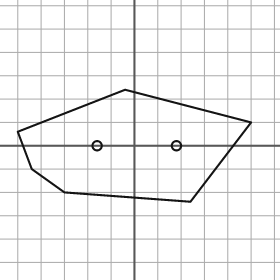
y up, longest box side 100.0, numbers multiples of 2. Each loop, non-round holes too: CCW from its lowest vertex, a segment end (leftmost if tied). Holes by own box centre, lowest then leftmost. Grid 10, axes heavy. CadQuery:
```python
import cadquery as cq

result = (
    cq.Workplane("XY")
    .moveTo(24.0, -24.0)
    .lineTo(50.0, 10.0)
    .lineTo(-4.0, 24.0)
    .lineTo(-50.0, 6.0)
    .lineTo(-44.0, -10.0)
    .lineTo(-30.0, -20.0)
    .close()
    .moveTo(-16.0, 0.0)
    .circle(2.0)
    .moveTo(18.0, 0.0)
    .circle(2.0)
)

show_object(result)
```